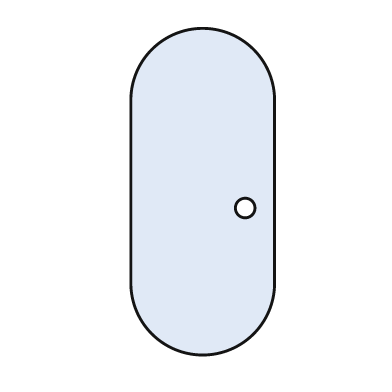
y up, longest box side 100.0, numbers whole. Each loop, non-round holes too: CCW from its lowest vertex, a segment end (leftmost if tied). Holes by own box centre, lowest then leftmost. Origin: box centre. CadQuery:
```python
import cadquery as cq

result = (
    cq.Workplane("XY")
    .moveTo(-22.0, -28.0)
    .threePointArc((0.0, -50.0), (22.0, -28.0))
    .lineTo(22.0, 28.0)
    .threePointArc((0.0, 50.0), (-22.0, 28.0))
    .close()
    .moveTo(13.0, -5.0)
    .circle(3.0)
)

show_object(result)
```